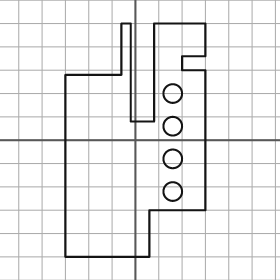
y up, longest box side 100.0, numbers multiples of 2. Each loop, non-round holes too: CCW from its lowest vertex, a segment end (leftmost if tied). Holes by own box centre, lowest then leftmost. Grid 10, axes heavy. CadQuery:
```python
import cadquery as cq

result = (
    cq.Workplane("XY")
    .moveTo(-30.0, -50.0)
    .lineTo(6.0, -50.0)
    .lineTo(6.0, -30.0)
    .lineTo(30.0, -30.0)
    .lineTo(30.0, 30.0)
    .lineTo(20.0, 30.0)
    .lineTo(20.0, 36.0)
    .lineTo(30.0, 36.0)
    .lineTo(30.0, 50.0)
    .lineTo(8.0, 50.0)
    .lineTo(8.0, 8.0)
    .lineTo(-2.0, 8.0)
    .lineTo(-2.0, 50.0)
    .lineTo(-6.0, 50.0)
    .lineTo(-6.0, 28.0)
    .lineTo(-30.0, 28.0)
    .close()
    .moveTo(16.0, -22.0)
    .circle(4.0)
    .moveTo(16.0, -8.0)
    .circle(4.0)
    .moveTo(16.0, 6.0)
    .circle(4.0)
    .moveTo(16.0, 20.0)
    .circle(4.0)
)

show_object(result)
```